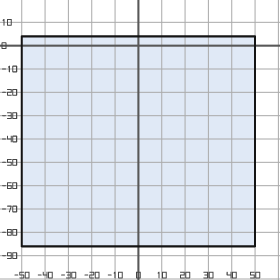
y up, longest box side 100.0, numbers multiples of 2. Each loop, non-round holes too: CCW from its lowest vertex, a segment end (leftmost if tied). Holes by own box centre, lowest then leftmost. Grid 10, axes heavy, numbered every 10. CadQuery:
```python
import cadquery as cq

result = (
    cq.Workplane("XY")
    .moveTo(-50.0, -86.0)
    .lineTo(50.0, -86.0)
    .lineTo(50.0, 4.0)
    .lineTo(-50.0, 4.0)
    .close()
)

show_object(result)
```